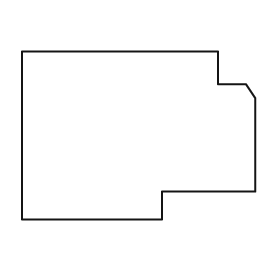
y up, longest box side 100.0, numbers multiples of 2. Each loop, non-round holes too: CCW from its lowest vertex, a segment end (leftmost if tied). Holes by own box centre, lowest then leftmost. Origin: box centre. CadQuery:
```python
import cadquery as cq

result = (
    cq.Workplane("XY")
    .moveTo(-50.0, -36.0)
    .lineTo(10.0, -36.0)
    .lineTo(10.0, -24.0)
    .lineTo(50.0, -24.0)
    .lineTo(50.0, 16.0)
    .lineTo(46.0, 22.0)
    .lineTo(34.0, 22.0)
    .lineTo(34.0, 36.0)
    .lineTo(-50.0, 36.0)
    .close()
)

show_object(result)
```